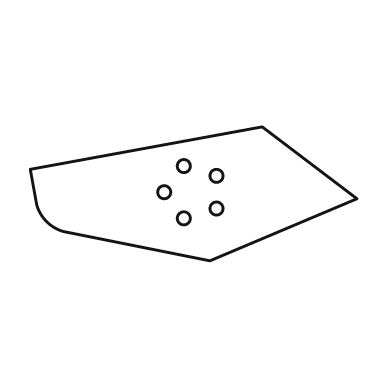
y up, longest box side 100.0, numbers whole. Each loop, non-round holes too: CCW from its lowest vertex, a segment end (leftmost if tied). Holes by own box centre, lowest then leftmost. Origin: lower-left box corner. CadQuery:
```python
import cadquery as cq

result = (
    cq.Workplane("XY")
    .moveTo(55.0, 0.0)
    .lineTo(100.0, 19.0)
    .lineTo(71.0, 41.0)
    .lineTo(0.0, 28.0)
    .lineTo(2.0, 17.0)
    .threePointArc((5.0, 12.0), (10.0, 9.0))
    .close()
    .moveTo(47.0, 13.0)
    .circle(2.0)
    .moveTo(57.0, 16.0)
    .circle(2.0)
    .moveTo(41.0, 21.0)
    .circle(2.0)
    .moveTo(57.0, 26.0)
    .circle(2.0)
    .moveTo(47.0, 29.0)
    .circle(2.0)
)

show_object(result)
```